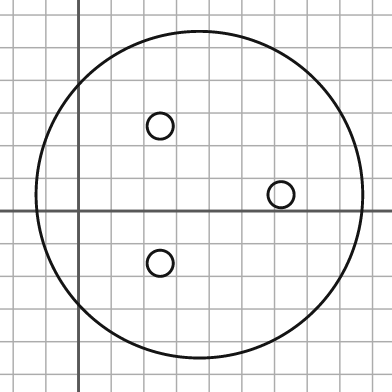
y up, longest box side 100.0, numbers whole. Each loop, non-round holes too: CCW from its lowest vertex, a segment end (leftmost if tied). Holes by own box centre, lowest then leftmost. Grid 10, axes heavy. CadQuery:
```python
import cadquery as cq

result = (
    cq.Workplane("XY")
    .moveTo(37.0, 5.0)
    .circle(50.0)
    .moveTo(25.0, -16.0)
    .circle(4.0)
    .moveTo(62.0, 5.0)
    .circle(4.0)
    .moveTo(25.0, 26.0)
    .circle(4.0)
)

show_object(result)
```